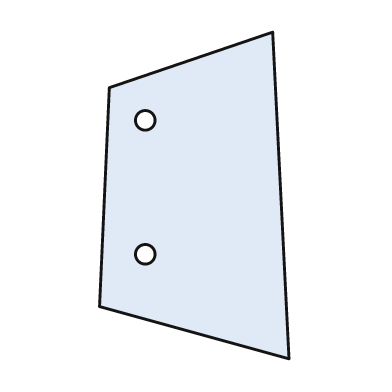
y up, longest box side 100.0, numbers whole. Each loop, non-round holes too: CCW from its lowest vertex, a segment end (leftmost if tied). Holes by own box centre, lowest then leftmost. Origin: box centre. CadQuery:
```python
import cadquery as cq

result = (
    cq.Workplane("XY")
    .moveTo(29.0, -50.0)
    .lineTo(24.0, 50.0)
    .lineTo(-26.0, 33.0)
    .lineTo(-29.0, -34.0)
    .close()
    .moveTo(-15.0, -18.0)
    .circle(3.0)
    .moveTo(-15.0, 23.0)
    .circle(3.0)
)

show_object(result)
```